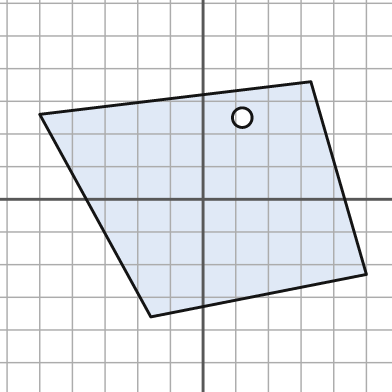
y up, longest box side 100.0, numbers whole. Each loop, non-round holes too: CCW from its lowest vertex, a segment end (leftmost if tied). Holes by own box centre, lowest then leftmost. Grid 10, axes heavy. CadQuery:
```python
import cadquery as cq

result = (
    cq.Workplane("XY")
    .moveTo(-16.0, -36.0)
    .lineTo(50.0, -23.0)
    .lineTo(33.0, 36.0)
    .lineTo(-50.0, 26.0)
    .close()
    .moveTo(12.0, 25.0)
    .circle(3.0)
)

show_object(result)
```